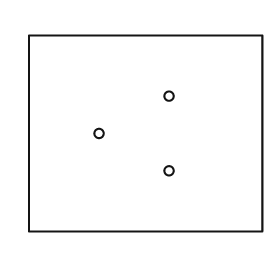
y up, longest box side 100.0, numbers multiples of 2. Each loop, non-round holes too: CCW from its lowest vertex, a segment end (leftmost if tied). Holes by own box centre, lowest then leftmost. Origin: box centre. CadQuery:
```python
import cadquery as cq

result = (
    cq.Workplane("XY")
    .moveTo(-50.0, -42.0)
    .lineTo(50.0, -42.0)
    .lineTo(50.0, 42.0)
    .lineTo(-50.0, 42.0)
    .close()
    .moveTo(10.0, -16.0)
    .circle(2.0)
    .moveTo(-20.0, 0.0)
    .circle(2.0)
    .moveTo(10.0, 16.0)
    .circle(2.0)
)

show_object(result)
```